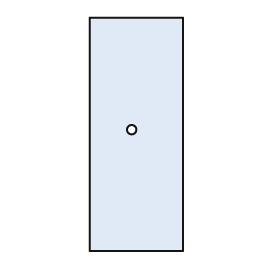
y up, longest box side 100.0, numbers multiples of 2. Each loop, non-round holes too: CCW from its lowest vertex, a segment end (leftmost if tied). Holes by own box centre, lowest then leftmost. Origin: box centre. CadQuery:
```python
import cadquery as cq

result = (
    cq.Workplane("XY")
    .moveTo(-20.0, -50.0)
    .lineTo(20.0, -50.0)
    .lineTo(20.0, 50.0)
    .lineTo(-20.0, 50.0)
    .close()
    .moveTo(-2.0, 2.0)
    .circle(2.0)
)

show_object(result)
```